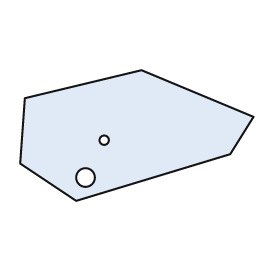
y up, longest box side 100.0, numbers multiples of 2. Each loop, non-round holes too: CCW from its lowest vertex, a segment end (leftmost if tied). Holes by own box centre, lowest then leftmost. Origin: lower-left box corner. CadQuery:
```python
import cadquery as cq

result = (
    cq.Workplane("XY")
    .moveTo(24.0, 0.0)
    .lineTo(90.0, 20.0)
    .lineTo(100.0, 36.0)
    .lineTo(52.0, 56.0)
    .lineTo(2.0, 44.0)
    .lineTo(0.0, 16.0)
    .close()
    .moveTo(28.0, 10.0)
    .circle(4.0)
    .moveTo(36.0, 26.0)
    .circle(2.0)
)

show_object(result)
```